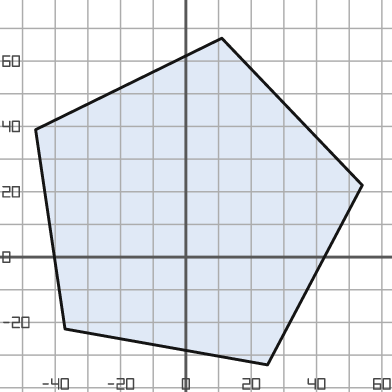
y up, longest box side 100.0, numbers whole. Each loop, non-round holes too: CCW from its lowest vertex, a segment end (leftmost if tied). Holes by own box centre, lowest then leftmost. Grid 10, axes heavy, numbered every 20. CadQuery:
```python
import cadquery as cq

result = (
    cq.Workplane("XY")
    .moveTo(25.0, -33.0)
    .lineTo(54.0, 22.0)
    .lineTo(11.0, 67.0)
    .lineTo(-46.0, 39.0)
    .lineTo(-37.0, -22.0)
    .close()
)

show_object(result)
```